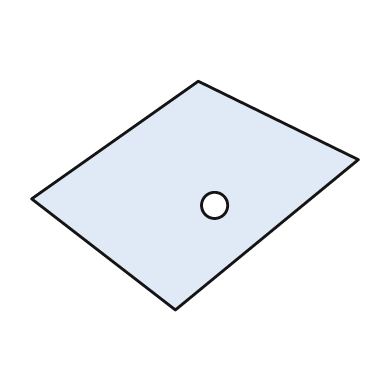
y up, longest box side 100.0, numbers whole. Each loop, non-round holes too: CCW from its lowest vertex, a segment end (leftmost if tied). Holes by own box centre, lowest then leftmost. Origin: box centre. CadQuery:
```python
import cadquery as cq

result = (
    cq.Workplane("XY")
    .moveTo(-6.0, -35.0)
    .lineTo(50.0, 11.0)
    .lineTo(1.0, 35.0)
    .lineTo(-50.0, -1.0)
    .close()
    .moveTo(6.0, -3.0)
    .circle(4.0)
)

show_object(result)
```